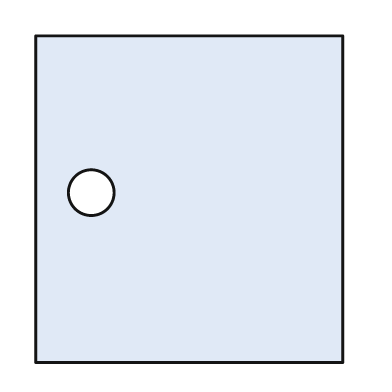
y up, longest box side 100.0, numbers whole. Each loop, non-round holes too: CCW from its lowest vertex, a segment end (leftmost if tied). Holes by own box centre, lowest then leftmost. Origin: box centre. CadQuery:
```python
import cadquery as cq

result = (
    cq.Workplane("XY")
    .moveTo(-47.0, -50.0)
    .lineTo(47.0, -50.0)
    .lineTo(47.0, 50.0)
    .lineTo(-47.0, 50.0)
    .close()
    .moveTo(-30.0, 2.0)
    .circle(7.0)
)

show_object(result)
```